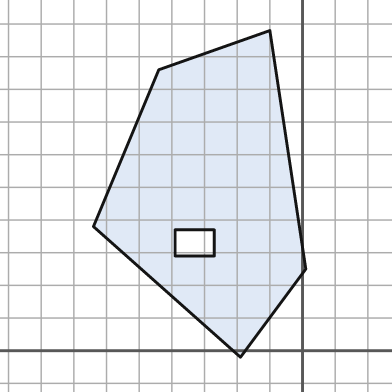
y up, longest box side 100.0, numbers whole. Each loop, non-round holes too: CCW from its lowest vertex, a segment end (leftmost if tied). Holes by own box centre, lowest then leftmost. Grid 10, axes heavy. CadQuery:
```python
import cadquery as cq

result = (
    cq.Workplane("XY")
    .moveTo(-19.0, -2.0)
    .lineTo(1.0, 25.0)
    .lineTo(-10.0, 98.0)
    .lineTo(-44.0, 86.0)
    .lineTo(-64.0, 38.0)
    .close()
    .moveTo(-39.0, 29.0)
    .lineTo(-27.0, 29.0)
    .lineTo(-27.0, 37.0)
    .lineTo(-39.0, 37.0)
    .close()
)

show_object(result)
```